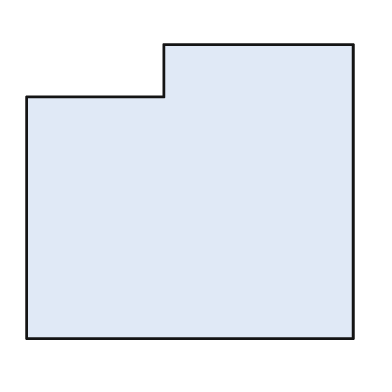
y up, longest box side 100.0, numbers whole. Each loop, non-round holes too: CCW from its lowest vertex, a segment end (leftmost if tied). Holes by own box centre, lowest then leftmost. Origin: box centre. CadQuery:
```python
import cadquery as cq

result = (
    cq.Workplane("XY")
    .moveTo(-50.0, -45.0)
    .lineTo(50.0, -45.0)
    .lineTo(50.0, 45.0)
    .lineTo(-8.0, 45.0)
    .lineTo(-8.0, 29.0)
    .lineTo(-50.0, 29.0)
    .close()
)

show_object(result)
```